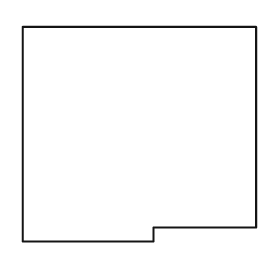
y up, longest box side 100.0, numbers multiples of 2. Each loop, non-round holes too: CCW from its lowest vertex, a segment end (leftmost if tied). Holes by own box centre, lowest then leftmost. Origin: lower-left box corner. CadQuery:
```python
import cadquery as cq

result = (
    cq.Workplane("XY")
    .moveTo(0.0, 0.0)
    .lineTo(56.0, 0.0)
    .lineTo(56.0, 6.0)
    .lineTo(100.0, 6.0)
    .lineTo(100.0, 92.0)
    .lineTo(0.0, 92.0)
    .close()
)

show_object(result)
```